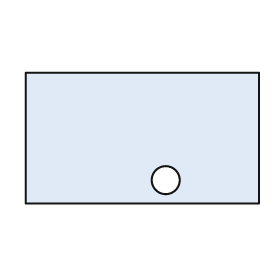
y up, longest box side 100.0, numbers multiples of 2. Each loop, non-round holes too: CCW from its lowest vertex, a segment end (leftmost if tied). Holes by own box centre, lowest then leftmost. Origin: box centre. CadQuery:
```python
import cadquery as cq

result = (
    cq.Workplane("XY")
    .moveTo(-50.0, -28.0)
    .lineTo(50.0, -28.0)
    .lineTo(50.0, 28.0)
    .lineTo(-50.0, 28.0)
    .close()
    .moveTo(10.0, -18.0)
    .circle(6.0)
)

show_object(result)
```